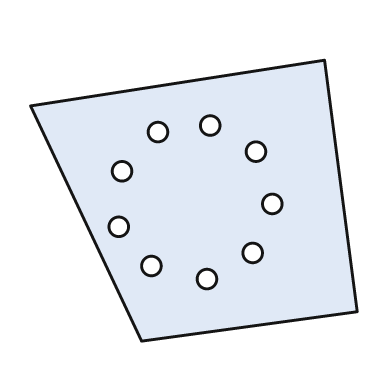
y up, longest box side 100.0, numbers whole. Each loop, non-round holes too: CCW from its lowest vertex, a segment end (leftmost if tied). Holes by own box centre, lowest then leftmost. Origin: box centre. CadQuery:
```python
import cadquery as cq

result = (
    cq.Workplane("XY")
    .moveTo(-16.0, -43.0)
    .lineTo(50.0, -34.0)
    .lineTo(40.0, 43.0)
    .lineTo(-50.0, 29.0)
    .close()
    .moveTo(4.0, -24.0)
    .circle(3.0)
    .moveTo(-13.0, -20.0)
    .circle(3.0)
    .moveTo(18.0, -16.0)
    .circle(3.0)
    .moveTo(-23.0, -8.0)
    .circle(3.0)
    .moveTo(24.0, -1.0)
    .circle(3.0)
    .moveTo(-22.0, 9.0)
    .circle(3.0)
    .moveTo(19.0, 15.0)
    .circle(3.0)
    .moveTo(-11.0, 21.0)
    .circle(3.0)
    .moveTo(5.0, 23.0)
    .circle(3.0)
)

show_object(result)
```